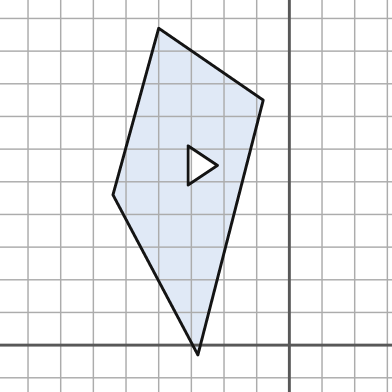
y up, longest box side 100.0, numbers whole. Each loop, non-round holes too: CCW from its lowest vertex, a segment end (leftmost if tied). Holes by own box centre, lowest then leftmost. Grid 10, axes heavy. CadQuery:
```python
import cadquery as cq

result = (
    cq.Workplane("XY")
    .moveTo(-28.0, -3.0)
    .lineTo(-8.0, 75.0)
    .lineTo(-40.0, 97.0)
    .lineTo(-54.0, 46.0)
    .close()
    .moveTo(-31.0, 49.0)
    .lineTo(-22.0, 55.0)
    .lineTo(-31.0, 61.0)
    .close()
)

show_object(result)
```